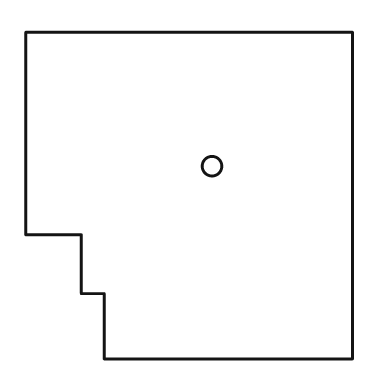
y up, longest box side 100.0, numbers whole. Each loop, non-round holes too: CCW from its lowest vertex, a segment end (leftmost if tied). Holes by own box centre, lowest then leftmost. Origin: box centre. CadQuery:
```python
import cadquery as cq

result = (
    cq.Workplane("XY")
    .moveTo(-26.0, -50.0)
    .lineTo(50.0, -50.0)
    .lineTo(50.0, 50.0)
    .lineTo(-50.0, 50.0)
    .lineTo(-50.0, -12.0)
    .lineTo(-33.0, -12.0)
    .lineTo(-33.0, -30.0)
    .lineTo(-26.0, -30.0)
    .close()
    .moveTo(7.0, 9.0)
    .circle(3.0)
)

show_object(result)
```